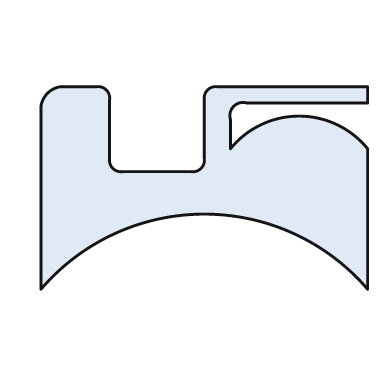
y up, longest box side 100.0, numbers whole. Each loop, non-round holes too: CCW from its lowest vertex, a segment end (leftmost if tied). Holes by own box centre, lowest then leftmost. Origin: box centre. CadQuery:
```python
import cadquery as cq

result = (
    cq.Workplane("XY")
    .moveTo(-50.0, -31.0)
    .threePointArc((0.0, -8.0), (50.0, -31.0))
    .lineTo(50.0, 12.0)
    .threePointArc((29.0, 22.0), (8.0, 12.0))
    .lineTo(8.0, 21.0)
    .threePointArc((9.0, 25.0), (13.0, 26.0))
    .lineTo(50.0, 26.0)
    .lineTo(50.0, 31.0)
    .lineTo(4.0, 31.0)
    .threePointArc((1.0, 30.0), (0.0, 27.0))
    .lineTo(0.0, 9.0)
    .threePointArc((-1.0, 6.0), (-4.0, 5.0))
    .lineTo(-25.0, 5.0)
    .threePointArc((-28.0, 6.0), (-29.0, 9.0))
    .lineTo(-29.0, 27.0)
    .threePointArc((-30.0, 30.0), (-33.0, 31.0))
    .lineTo(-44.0, 31.0)
    .threePointArc((-48.0, 29.0), (-50.0, 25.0))
    .close()
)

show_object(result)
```